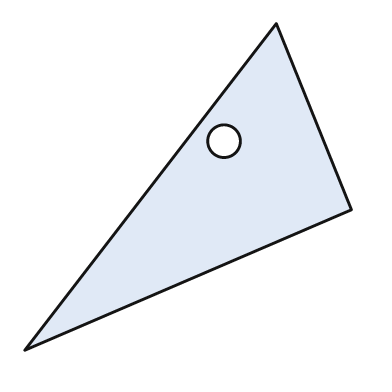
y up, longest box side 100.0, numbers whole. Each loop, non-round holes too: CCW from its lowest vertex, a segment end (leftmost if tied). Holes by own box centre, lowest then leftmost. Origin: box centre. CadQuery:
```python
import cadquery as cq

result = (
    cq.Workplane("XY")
    .moveTo(-50.0, -50.0)
    .lineTo(50.0, -7.0)
    .lineTo(27.0, 50.0)
    .close()
    .moveTo(11.0, 14.0)
    .circle(5.0)
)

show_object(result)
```